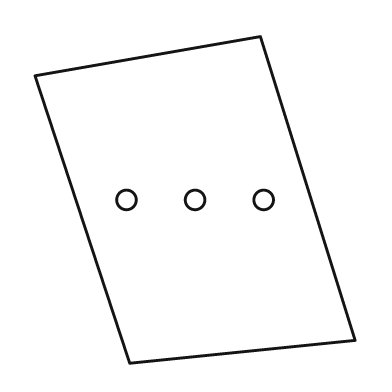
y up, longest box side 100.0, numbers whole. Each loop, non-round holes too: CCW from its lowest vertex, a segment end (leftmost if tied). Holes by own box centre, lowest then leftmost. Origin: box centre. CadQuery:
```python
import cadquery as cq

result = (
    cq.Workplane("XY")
    .moveTo(-20.0, -50.0)
    .lineTo(49.0, -43.0)
    .lineTo(20.0, 50.0)
    .lineTo(-49.0, 38.0)
    .close()
    .moveTo(-21.0, 0.0)
    .circle(3.0)
    .moveTo(0.0, 0.0)
    .circle(3.0)
    .moveTo(21.0, 0.0)
    .circle(3.0)
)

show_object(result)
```